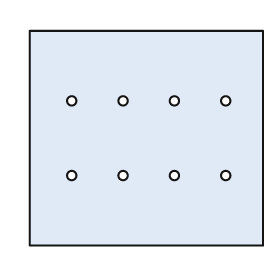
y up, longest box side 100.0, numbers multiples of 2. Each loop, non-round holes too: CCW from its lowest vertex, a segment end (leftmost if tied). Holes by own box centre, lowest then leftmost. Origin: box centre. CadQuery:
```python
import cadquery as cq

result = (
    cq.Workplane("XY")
    .moveTo(-50.0, -46.0)
    .lineTo(50.0, -46.0)
    .lineTo(50.0, 46.0)
    .lineTo(-50.0, 46.0)
    .close()
    .moveTo(-32.0, -16.0)
    .circle(2.0)
    .moveTo(-10.0, -16.0)
    .circle(2.0)
    .moveTo(12.0, -16.0)
    .circle(2.0)
    .moveTo(34.0, -16.0)
    .circle(2.0)
    .moveTo(-32.0, 16.0)
    .circle(2.0)
    .moveTo(-10.0, 16.0)
    .circle(2.0)
    .moveTo(12.0, 16.0)
    .circle(2.0)
    .moveTo(34.0, 16.0)
    .circle(2.0)
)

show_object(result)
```